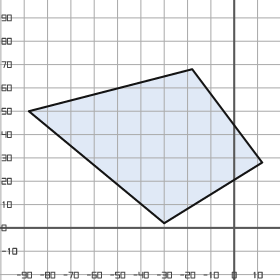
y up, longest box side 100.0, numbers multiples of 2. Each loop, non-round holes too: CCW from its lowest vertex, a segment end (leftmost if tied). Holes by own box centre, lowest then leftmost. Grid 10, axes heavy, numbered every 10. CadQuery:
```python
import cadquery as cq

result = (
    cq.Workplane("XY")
    .moveTo(-30.0, 2.0)
    .lineTo(12.0, 28.0)
    .lineTo(-18.0, 68.0)
    .lineTo(-88.0, 50.0)
    .close()
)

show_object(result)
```